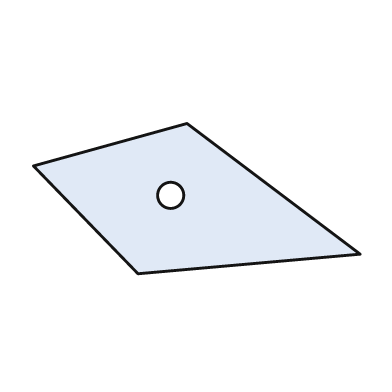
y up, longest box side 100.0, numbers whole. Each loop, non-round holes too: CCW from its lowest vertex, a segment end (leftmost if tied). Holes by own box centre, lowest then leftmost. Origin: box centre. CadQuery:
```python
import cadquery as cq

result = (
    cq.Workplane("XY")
    .moveTo(-18.0, -23.0)
    .lineTo(50.0, -17.0)
    .lineTo(-3.0, 23.0)
    .lineTo(-50.0, 10.0)
    .close()
    .moveTo(-8.0, 1.0)
    .circle(4.0)
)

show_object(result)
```